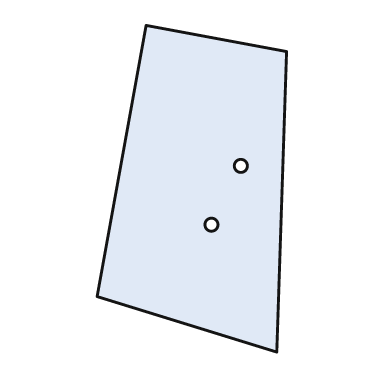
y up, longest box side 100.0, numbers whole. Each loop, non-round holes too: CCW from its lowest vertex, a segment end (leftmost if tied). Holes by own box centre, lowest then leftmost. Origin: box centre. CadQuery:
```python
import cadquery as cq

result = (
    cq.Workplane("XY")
    .moveTo(26.0, -50.0)
    .lineTo(29.0, 42.0)
    .lineTo(-14.0, 50.0)
    .lineTo(-29.0, -33.0)
    .close()
    .moveTo(6.0, -11.0)
    .circle(2.0)
    .moveTo(15.0, 7.0)
    .circle(2.0)
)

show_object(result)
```